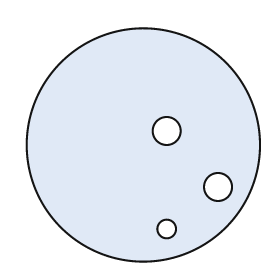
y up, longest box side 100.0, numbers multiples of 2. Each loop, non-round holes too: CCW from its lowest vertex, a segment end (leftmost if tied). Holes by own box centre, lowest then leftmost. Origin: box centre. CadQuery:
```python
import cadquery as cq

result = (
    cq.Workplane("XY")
    .moveTo(0.0, 0.0)
    .circle(50.0)
    .moveTo(10.0, -36.0)
    .circle(4.0)
    .moveTo(32.0, -18.0)
    .circle(6.0)
    .moveTo(10.0, 6.0)
    .circle(6.0)
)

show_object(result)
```